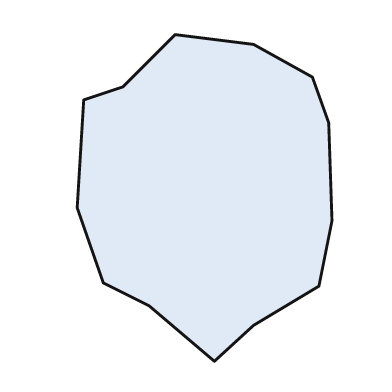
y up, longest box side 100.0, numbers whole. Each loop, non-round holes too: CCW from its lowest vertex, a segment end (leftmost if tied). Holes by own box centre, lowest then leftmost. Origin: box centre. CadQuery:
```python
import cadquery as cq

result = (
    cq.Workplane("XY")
    .moveTo(3.0, -50.0)
    .lineTo(15.0, -39.0)
    .lineTo(35.0, -27.0)
    .lineTo(39.0, -7.0)
    .lineTo(38.0, 23.0)
    .lineTo(33.0, 37.0)
    .lineTo(15.0, 47.0)
    .lineTo(-9.0, 50.0)
    .lineTo(-25.0, 34.0)
    .lineTo(-37.0, 30.0)
    .lineTo(-39.0, -3.0)
    .lineTo(-31.0, -26.0)
    .lineTo(-17.0, -33.0)
    .close()
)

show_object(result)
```